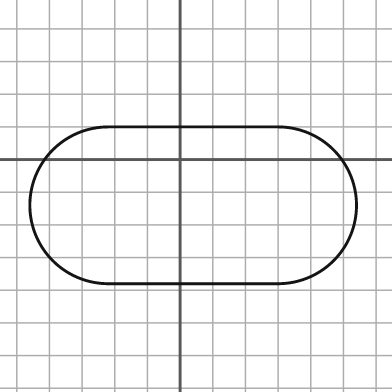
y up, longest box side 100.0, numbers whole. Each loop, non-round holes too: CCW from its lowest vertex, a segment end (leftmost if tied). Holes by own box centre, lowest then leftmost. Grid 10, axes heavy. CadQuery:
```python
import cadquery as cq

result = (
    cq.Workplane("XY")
    .moveTo(-22.0, -38.0)
    .lineTo(30.0, -38.0)
    .threePointArc((54.0, -14.0), (30.0, 10.0))
    .lineTo(-22.0, 10.0)
    .threePointArc((-46.0, -14.0), (-22.0, -38.0))
    .close()
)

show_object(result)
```